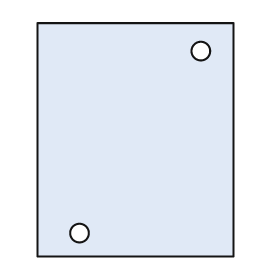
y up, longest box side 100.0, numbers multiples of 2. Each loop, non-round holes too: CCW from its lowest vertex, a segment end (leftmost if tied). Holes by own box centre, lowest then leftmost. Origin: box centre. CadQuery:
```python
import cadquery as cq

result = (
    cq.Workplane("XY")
    .moveTo(-42.0, -50.0)
    .lineTo(42.0, -50.0)
    .lineTo(42.0, 50.0)
    .lineTo(-42.0, 50.0)
    .close()
    .moveTo(-24.0, -40.0)
    .circle(4.0)
    .moveTo(28.0, 38.0)
    .circle(4.0)
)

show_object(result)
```